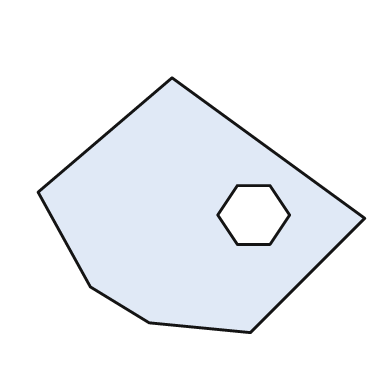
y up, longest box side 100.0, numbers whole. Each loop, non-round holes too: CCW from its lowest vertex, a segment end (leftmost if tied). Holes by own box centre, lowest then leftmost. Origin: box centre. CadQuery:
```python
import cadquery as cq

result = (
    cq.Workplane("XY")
    .moveTo(15.0, -39.0)
    .lineTo(50.0, -4.0)
    .lineTo(-9.0, 39.0)
    .lineTo(-50.0, 4.0)
    .lineTo(-34.0, -25.0)
    .lineTo(-16.0, -36.0)
    .close()
    .moveTo(11.0, -12.0)
    .lineTo(21.0, -12.0)
    .lineTo(27.0, -3.0)
    .lineTo(21.0, 6.0)
    .lineTo(11.0, 6.0)
    .lineTo(5.0, -3.0)
    .close()
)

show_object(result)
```